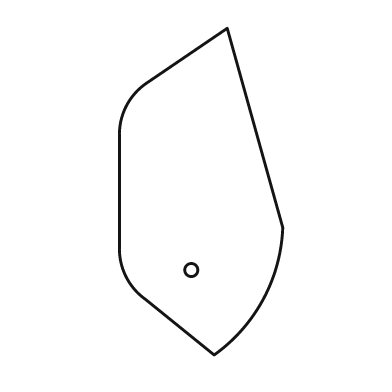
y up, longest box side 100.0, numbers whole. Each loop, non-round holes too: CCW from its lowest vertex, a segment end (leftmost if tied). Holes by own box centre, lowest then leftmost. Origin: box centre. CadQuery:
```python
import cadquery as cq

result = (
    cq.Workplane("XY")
    .moveTo(4.0, -50.0)
    .threePointArc((19.0, -33.0), (25.0, -11.0))
    .lineTo(8.0, 50.0)
    .lineTo(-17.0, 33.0)
    .threePointArc((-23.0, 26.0), (-25.0, 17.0))
    .lineTo(-25.0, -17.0)
    .threePointArc((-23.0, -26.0), (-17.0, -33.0))
    .close()
    .moveTo(-3.0, -24.0)
    .circle(2.0)
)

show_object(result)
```